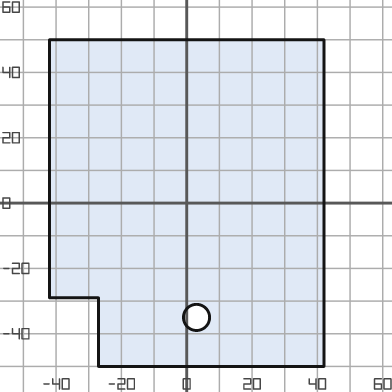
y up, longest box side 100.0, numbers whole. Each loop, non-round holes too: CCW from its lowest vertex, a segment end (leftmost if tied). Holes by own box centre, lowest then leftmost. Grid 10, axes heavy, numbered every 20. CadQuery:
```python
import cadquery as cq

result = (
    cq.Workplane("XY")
    .moveTo(-27.0, -50.0)
    .lineTo(42.0, -50.0)
    .lineTo(42.0, 50.0)
    .lineTo(-42.0, 50.0)
    .lineTo(-42.0, -29.0)
    .lineTo(-27.0, -29.0)
    .close()
    .moveTo(3.0, -35.0)
    .circle(4.0)
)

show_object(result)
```